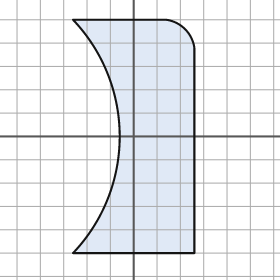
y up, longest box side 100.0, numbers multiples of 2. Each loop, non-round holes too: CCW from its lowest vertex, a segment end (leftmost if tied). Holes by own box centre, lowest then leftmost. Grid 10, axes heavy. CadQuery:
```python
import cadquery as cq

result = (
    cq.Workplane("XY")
    .moveTo(-26.0, -50.0)
    .lineTo(26.0, -50.0)
    .lineTo(26.0, 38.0)
    .threePointArc((22.0, 46.0), (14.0, 50.0))
    .lineTo(-26.0, 50.0)
    .threePointArc((-6.0, 0.0), (-26.0, -50.0))
    .close()
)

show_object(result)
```